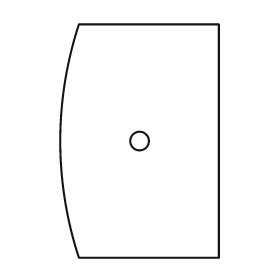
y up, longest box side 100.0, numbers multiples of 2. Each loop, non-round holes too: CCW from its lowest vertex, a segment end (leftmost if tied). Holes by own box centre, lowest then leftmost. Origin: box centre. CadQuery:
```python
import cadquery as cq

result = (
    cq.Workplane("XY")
    .moveTo(-26.0, -50.0)
    .lineTo(34.0, -50.0)
    .lineTo(34.0, 50.0)
    .lineTo(-26.0, 50.0)
    .threePointArc((-34.0, 0.0), (-26.0, -50.0))
    .close()
    .moveTo(0.0, 0.0)
    .circle(4.0)
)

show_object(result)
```